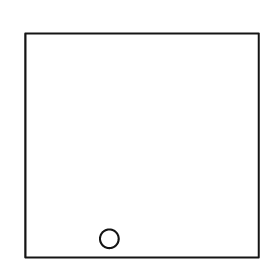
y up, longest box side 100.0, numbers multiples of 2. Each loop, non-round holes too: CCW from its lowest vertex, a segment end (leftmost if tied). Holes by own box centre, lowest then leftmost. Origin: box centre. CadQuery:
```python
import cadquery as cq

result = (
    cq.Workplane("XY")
    .moveTo(-50.0, -48.0)
    .lineTo(50.0, -48.0)
    .lineTo(50.0, 48.0)
    .lineTo(-50.0, 48.0)
    .close()
    .moveTo(-14.0, -40.0)
    .circle(4.0)
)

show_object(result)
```